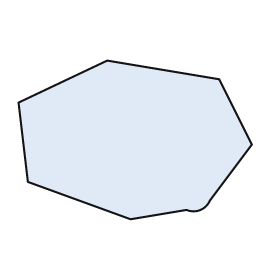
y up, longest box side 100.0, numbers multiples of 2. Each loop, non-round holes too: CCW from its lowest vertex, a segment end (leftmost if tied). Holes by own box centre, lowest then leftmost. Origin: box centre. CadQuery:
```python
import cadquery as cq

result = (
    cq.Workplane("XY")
    .moveTo(-2.0, -34.0)
    .lineTo(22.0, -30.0)
    .threePointArc((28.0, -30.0), (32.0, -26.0))
    .lineTo(50.0, -2.0)
    .lineTo(36.0, 26.0)
    .lineTo(-12.0, 34.0)
    .lineTo(-50.0, 16.0)
    .lineTo(-46.0, -18.0)
    .close()
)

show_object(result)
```